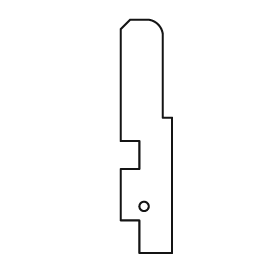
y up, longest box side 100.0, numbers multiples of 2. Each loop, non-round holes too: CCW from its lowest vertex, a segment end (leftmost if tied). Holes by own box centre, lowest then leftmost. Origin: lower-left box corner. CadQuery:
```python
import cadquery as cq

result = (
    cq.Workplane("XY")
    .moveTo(8.0, 0.0)
    .lineTo(22.0, 0.0)
    .lineTo(22.0, 58.0)
    .lineTo(18.0, 58.0)
    .lineTo(18.0, 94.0)
    .threePointArc((16.0, 98.0), (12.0, 100.0))
    .lineTo(4.0, 100.0)
    .lineTo(0.0, 96.0)
    .lineTo(0.0, 48.0)
    .lineTo(8.0, 48.0)
    .lineTo(8.0, 36.0)
    .lineTo(0.0, 36.0)
    .lineTo(0.0, 14.0)
    .lineTo(8.0, 14.0)
    .close()
    .moveTo(10.0, 20.0)
    .circle(2.0)
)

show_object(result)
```